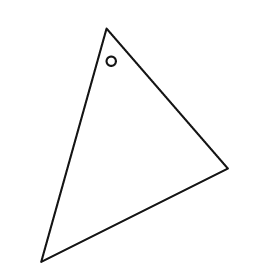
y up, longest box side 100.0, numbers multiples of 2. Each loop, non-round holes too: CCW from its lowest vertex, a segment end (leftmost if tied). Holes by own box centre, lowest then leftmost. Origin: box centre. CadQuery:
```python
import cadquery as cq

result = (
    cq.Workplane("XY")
    .moveTo(-40.0, -50.0)
    .lineTo(40.0, -10.0)
    .lineTo(-12.0, 50.0)
    .close()
    .moveTo(-10.0, 36.0)
    .circle(2.0)
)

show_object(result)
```